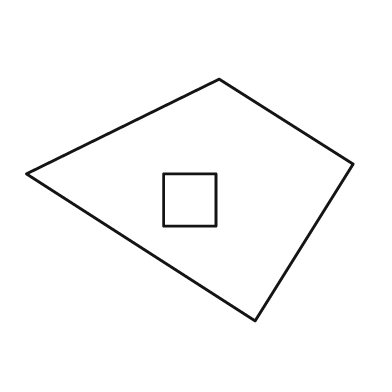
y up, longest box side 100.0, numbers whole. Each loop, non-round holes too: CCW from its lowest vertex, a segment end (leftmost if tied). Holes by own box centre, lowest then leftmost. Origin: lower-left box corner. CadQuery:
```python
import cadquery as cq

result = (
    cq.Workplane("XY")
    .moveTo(70.0, 0.0)
    .lineTo(100.0, 48.0)
    .lineTo(59.0, 74.0)
    .lineTo(0.0, 45.0)
    .close()
    .moveTo(42.0, 29.0)
    .lineTo(58.0, 29.0)
    .lineTo(58.0, 45.0)
    .lineTo(42.0, 45.0)
    .close()
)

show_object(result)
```